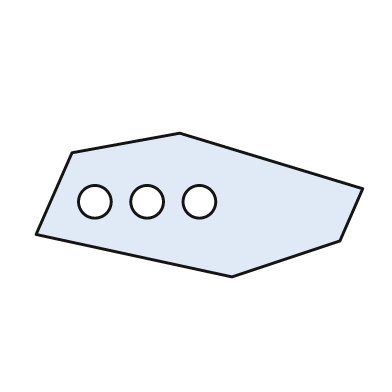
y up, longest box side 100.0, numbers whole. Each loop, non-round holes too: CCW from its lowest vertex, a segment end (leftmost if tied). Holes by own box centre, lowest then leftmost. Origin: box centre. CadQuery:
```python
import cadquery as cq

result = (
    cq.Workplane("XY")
    .moveTo(10.0, -22.0)
    .lineTo(43.0, -11.0)
    .lineTo(50.0, 5.0)
    .lineTo(-6.0, 22.0)
    .lineTo(-39.0, 16.0)
    .lineTo(-50.0, -9.0)
    .close()
    .moveTo(-32.0, 1.0)
    .circle(5.0)
    .moveTo(-16.0, 1.0)
    .circle(5.0)
    .moveTo(0.0, 1.0)
    .circle(5.0)
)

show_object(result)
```